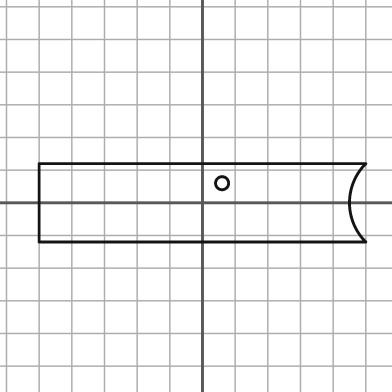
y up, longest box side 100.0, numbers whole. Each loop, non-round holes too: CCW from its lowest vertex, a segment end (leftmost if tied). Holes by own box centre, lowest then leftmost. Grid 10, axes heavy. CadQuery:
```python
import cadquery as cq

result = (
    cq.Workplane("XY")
    .moveTo(-50.0, -12.0)
    .lineTo(50.0, -12.0)
    .threePointArc((45.0, 0.0), (50.0, 12.0))
    .lineTo(-50.0, 12.0)
    .close()
    .moveTo(6.0, 6.0)
    .circle(2.0)
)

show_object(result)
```